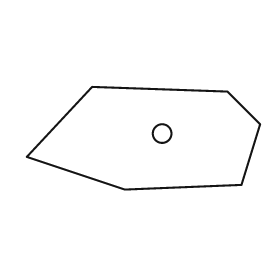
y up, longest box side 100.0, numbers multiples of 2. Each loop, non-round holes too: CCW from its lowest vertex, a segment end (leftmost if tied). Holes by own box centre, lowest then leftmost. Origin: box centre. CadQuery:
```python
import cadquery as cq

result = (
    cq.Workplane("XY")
    .moveTo(-8.0, -22.0)
    .lineTo(42.0, -20.0)
    .lineTo(50.0, 6.0)
    .lineTo(36.0, 20.0)
    .lineTo(-22.0, 22.0)
    .lineTo(-50.0, -8.0)
    .close()
    .moveTo(8.0, 2.0)
    .circle(4.0)
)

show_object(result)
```